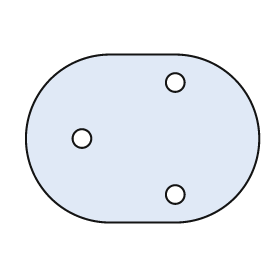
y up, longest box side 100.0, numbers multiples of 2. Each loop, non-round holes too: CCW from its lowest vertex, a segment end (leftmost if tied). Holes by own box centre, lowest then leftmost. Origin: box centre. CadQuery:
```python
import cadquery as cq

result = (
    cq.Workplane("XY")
    .moveTo(-14.0, -36.0)
    .lineTo(14.0, -36.0)
    .threePointArc((50.0, 0.0), (14.0, 36.0))
    .lineTo(-14.0, 36.0)
    .threePointArc((-50.0, 0.0), (-14.0, -36.0))
    .close()
    .moveTo(14.0, -24.0)
    .circle(4.0)
    .moveTo(-26.0, 0.0)
    .circle(4.0)
    .moveTo(14.0, 24.0)
    .circle(4.0)
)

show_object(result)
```